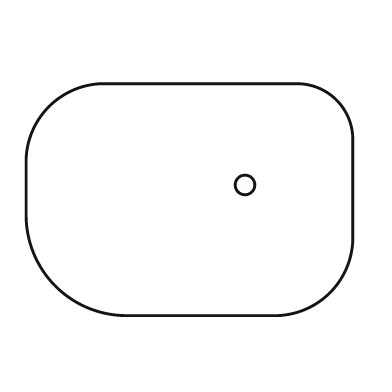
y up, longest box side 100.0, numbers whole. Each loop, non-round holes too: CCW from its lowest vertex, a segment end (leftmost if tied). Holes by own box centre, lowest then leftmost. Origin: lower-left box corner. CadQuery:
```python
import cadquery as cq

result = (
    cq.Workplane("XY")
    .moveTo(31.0, 0.0)
    .lineTo(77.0, 0.0)
    .threePointArc((93.0, 7.0), (100.0, 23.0))
    .lineTo(100.0, 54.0)
    .threePointArc((95.0, 66.0), (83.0, 71.0))
    .lineTo(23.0, 71.0)
    .threePointArc((7.0, 64.0), (0.0, 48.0))
    .lineTo(0.0, 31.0)
    .threePointArc((9.0, 9.0), (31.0, 0.0))
    .close()
    .moveTo(67.0, 40.0)
    .circle(3.0)
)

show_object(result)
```